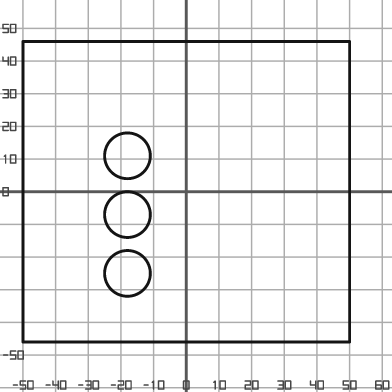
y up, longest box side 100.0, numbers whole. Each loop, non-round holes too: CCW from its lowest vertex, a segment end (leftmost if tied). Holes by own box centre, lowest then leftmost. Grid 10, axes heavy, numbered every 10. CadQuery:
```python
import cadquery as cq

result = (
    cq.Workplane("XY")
    .moveTo(-50.0, -46.0)
    .lineTo(50.0, -46.0)
    .lineTo(50.0, 46.0)
    .lineTo(-50.0, 46.0)
    .close()
    .moveTo(-18.0, -25.0)
    .circle(7.0)
    .moveTo(-18.0, -7.0)
    .circle(7.0)
    .moveTo(-18.0, 11.0)
    .circle(7.0)
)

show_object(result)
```